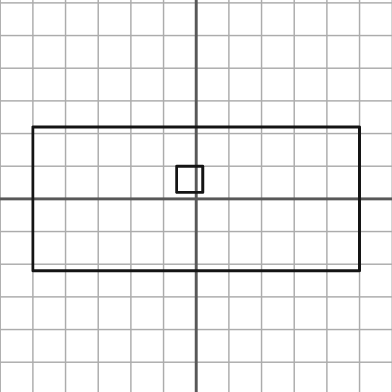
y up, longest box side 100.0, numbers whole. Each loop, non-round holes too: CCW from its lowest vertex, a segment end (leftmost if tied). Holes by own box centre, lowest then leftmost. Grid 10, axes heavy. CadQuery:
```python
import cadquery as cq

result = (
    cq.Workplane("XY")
    .moveTo(-50.0, -22.0)
    .lineTo(50.0, -22.0)
    .lineTo(50.0, 22.0)
    .lineTo(-50.0, 22.0)
    .close()
    .moveTo(-6.0, 2.0)
    .lineTo(2.0, 2.0)
    .lineTo(2.0, 10.0)
    .lineTo(-6.0, 10.0)
    .close()
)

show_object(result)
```